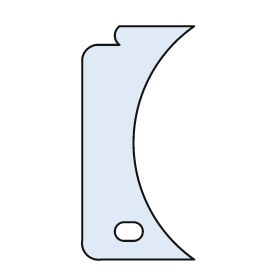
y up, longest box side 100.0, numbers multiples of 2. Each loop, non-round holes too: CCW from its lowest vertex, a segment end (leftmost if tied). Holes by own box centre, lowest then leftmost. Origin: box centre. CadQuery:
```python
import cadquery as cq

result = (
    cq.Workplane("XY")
    .moveTo(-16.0, -50.0)
    .lineTo(24.0, -50.0)
    .threePointArc((-2.0, 0.0), (24.0, 50.0))
    .lineTo(-8.0, 50.0)
    .threePointArc((-10.0, 46.0), (-8.0, 42.0))
    .lineTo(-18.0, 42.0)
    .threePointArc((-22.0, 40.0), (-24.0, 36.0))
    .lineTo(-24.0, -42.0)
    .threePointArc((-22.0, -48.0), (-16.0, -50.0))
    .close()
    .moveTo(-6.0, -42.0)
    .lineTo(-2.0, -42.0)
    .threePointArc((2.0, -38.0), (-2.0, -34.0))
    .lineTo(-6.0, -34.0)
    .threePointArc((-10.0, -38.0), (-6.0, -42.0))
    .close()
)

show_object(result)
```